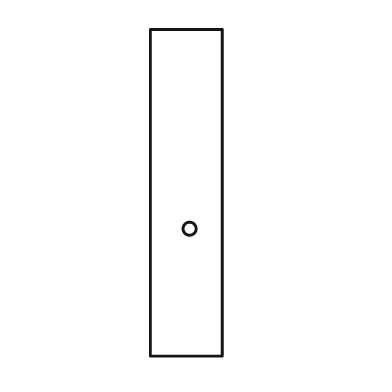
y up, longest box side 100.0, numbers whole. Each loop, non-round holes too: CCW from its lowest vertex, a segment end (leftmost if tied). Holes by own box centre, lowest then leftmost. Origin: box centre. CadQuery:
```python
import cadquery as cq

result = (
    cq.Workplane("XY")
    .moveTo(-11.0, -50.0)
    .lineTo(11.0, -50.0)
    .lineTo(11.0, 50.0)
    .lineTo(-11.0, 50.0)
    .close()
    .moveTo(1.0, -11.0)
    .circle(2.0)
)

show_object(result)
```